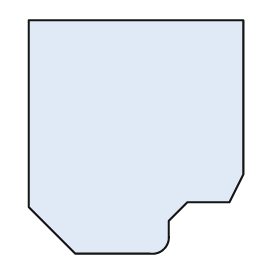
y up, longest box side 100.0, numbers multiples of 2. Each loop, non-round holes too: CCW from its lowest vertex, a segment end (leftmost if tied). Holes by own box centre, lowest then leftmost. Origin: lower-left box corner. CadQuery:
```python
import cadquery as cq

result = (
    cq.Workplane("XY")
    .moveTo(20.0, 0.0)
    .lineTo(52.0, 0.0)
    .threePointArc((58.0, 2.0), (60.0, 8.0))
    .lineTo(60.0, 14.0)
    .lineTo(68.0, 22.0)
    .lineTo(86.0, 22.0)
    .lineTo(92.0, 34.0)
    .lineTo(92.0, 100.0)
    .lineTo(0.0, 100.0)
    .lineTo(0.0, 20.0)
    .close()
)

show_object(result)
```